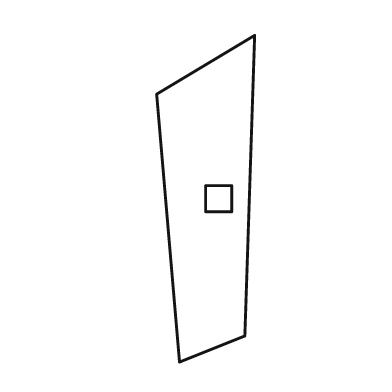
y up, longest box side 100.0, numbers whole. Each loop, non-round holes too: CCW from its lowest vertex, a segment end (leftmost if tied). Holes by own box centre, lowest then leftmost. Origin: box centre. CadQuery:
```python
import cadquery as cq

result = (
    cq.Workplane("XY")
    .moveTo(-8.0, -50.0)
    .lineTo(12.0, -42.0)
    .lineTo(15.0, 50.0)
    .lineTo(-15.0, 32.0)
    .close()
    .moveTo(0.0, -4.0)
    .lineTo(8.0, -4.0)
    .lineTo(8.0, 4.0)
    .lineTo(0.0, 4.0)
    .close()
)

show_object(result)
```